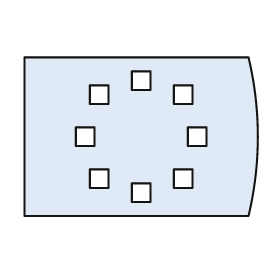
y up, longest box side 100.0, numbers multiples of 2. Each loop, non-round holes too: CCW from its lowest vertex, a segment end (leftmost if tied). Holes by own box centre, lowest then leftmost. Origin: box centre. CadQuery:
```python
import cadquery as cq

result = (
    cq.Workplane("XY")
    .moveTo(-50.0, -34.0)
    .lineTo(46.0, -34.0)
    .threePointArc((50.0, 0.0), (46.0, 34.0))
    .lineTo(-50.0, 34.0)
    .close()
    .moveTo(-4.0, -28.0)
    .lineTo(4.0, -28.0)
    .lineTo(4.0, -20.0)
    .lineTo(-4.0, -20.0)
    .close()
    .moveTo(-22.0, -22.0)
    .lineTo(-14.0, -22.0)
    .lineTo(-14.0, -14.0)
    .lineTo(-22.0, -14.0)
    .close()
    .moveTo(14.0, -22.0)
    .lineTo(22.0, -22.0)
    .lineTo(22.0, -14.0)
    .lineTo(14.0, -14.0)
    .close()
    .moveTo(-28.0, -4.0)
    .lineTo(-20.0, -4.0)
    .lineTo(-20.0, 4.0)
    .lineTo(-28.0, 4.0)
    .close()
    .moveTo(20.0, -4.0)
    .lineTo(28.0, -4.0)
    .lineTo(28.0, 4.0)
    .lineTo(20.0, 4.0)
    .close()
    .moveTo(-22.0, 14.0)
    .lineTo(-14.0, 14.0)
    .lineTo(-14.0, 22.0)
    .lineTo(-22.0, 22.0)
    .close()
    .moveTo(14.0, 14.0)
    .lineTo(22.0, 14.0)
    .lineTo(22.0, 22.0)
    .lineTo(14.0, 22.0)
    .close()
    .moveTo(-4.0, 20.0)
    .lineTo(4.0, 20.0)
    .lineTo(4.0, 28.0)
    .lineTo(-4.0, 28.0)
    .close()
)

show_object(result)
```